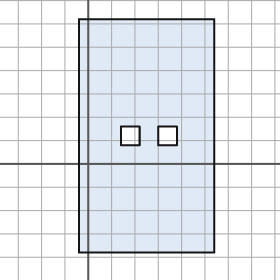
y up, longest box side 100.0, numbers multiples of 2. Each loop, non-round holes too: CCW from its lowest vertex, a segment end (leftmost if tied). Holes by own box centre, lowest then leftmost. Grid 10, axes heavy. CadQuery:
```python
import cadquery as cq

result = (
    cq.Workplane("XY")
    .moveTo(-4.0, -38.0)
    .lineTo(54.0, -38.0)
    .lineTo(54.0, 62.0)
    .lineTo(-4.0, 62.0)
    .close()
    .moveTo(14.0, 8.0)
    .lineTo(22.0, 8.0)
    .lineTo(22.0, 16.0)
    .lineTo(14.0, 16.0)
    .close()
    .moveTo(30.0, 8.0)
    .lineTo(38.0, 8.0)
    .lineTo(38.0, 16.0)
    .lineTo(30.0, 16.0)
    .close()
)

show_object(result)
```